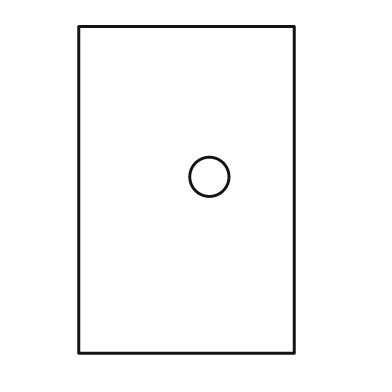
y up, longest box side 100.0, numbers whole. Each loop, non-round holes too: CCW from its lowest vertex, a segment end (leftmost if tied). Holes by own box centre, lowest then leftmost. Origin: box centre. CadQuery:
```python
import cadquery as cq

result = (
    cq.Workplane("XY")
    .moveTo(-33.0, -50.0)
    .lineTo(33.0, -50.0)
    .lineTo(33.0, 50.0)
    .lineTo(-33.0, 50.0)
    .close()
    .moveTo(7.0, 4.0)
    .circle(6.0)
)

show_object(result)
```